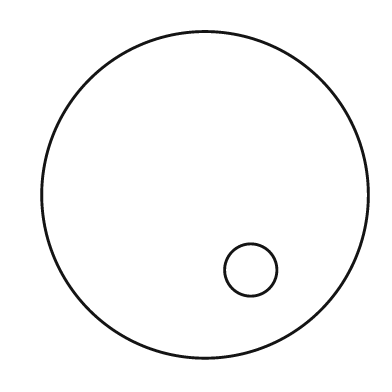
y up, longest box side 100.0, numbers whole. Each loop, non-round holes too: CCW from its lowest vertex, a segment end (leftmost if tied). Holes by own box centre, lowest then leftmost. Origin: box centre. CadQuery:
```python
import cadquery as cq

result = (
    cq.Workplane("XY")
    .moveTo(0.0, 0.0)
    .circle(50.0)
    .moveTo(14.0, -23.0)
    .circle(8.0)
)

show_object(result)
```